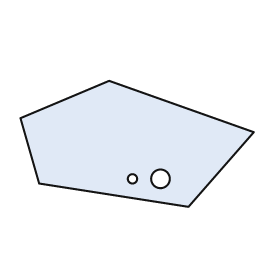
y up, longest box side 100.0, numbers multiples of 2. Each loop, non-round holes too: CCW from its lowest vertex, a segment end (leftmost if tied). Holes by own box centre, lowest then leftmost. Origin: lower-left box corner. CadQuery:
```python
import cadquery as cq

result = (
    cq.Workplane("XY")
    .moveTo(72.0, 0.0)
    .lineTo(100.0, 32.0)
    .lineTo(38.0, 54.0)
    .lineTo(0.0, 38.0)
    .lineTo(8.0, 10.0)
    .close()
    .moveTo(48.0, 12.0)
    .circle(2.0)
    .moveTo(60.0, 12.0)
    .circle(4.0)
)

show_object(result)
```